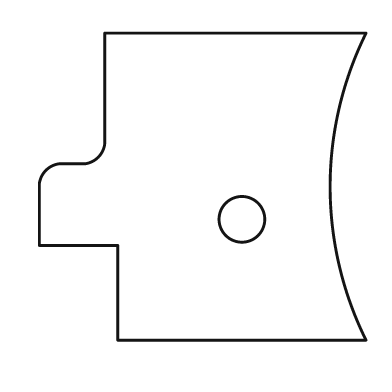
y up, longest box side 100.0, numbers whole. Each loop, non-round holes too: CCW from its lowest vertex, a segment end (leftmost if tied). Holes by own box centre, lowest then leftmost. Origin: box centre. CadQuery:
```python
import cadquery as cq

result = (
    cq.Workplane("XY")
    .moveTo(-26.0, -47.0)
    .lineTo(50.0, -47.0)
    .threePointArc((39.0, 0.0), (50.0, 47.0))
    .lineTo(-30.0, 47.0)
    .lineTo(-30.0, 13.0)
    .threePointArc((-32.0, 9.0), (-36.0, 7.0))
    .lineTo(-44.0, 7.0)
    .threePointArc((-48.0, 5.0), (-50.0, 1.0))
    .lineTo(-50.0, -18.0)
    .lineTo(-26.0, -18.0)
    .close()
    .moveTo(12.0, -10.0)
    .circle(7.0)
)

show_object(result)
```